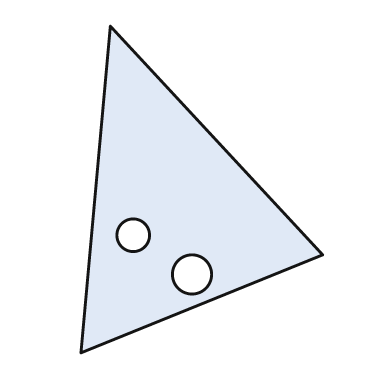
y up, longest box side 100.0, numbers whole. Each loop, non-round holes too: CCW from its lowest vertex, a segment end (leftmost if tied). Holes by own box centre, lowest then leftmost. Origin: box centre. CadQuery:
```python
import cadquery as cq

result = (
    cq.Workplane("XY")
    .moveTo(-37.0, -50.0)
    .lineTo(37.0, -20.0)
    .lineTo(-28.0, 50.0)
    .close()
    .moveTo(-3.0, -26.0)
    .circle(6.0)
    .moveTo(-21.0, -14.0)
    .circle(5.0)
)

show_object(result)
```